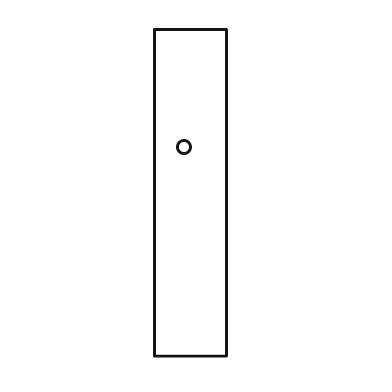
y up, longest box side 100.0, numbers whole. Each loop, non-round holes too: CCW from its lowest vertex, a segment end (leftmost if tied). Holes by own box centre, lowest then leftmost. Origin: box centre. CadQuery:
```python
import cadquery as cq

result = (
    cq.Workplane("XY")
    .moveTo(-11.0, -50.0)
    .lineTo(11.0, -50.0)
    .lineTo(11.0, 50.0)
    .lineTo(-11.0, 50.0)
    .close()
    .moveTo(-2.0, 14.0)
    .circle(2.0)
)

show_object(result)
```